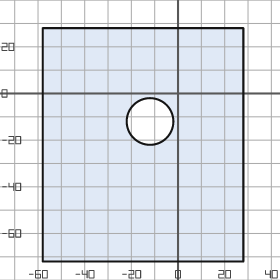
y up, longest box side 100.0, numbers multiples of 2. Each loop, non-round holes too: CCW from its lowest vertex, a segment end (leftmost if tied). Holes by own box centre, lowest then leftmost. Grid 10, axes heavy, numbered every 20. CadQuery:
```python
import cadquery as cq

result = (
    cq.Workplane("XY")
    .moveTo(-58.0, -72.0)
    .lineTo(28.0, -72.0)
    .lineTo(28.0, 28.0)
    .lineTo(-58.0, 28.0)
    .close()
    .moveTo(-12.0, -12.0)
    .circle(10.0)
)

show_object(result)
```